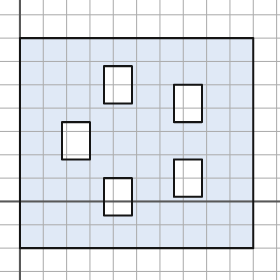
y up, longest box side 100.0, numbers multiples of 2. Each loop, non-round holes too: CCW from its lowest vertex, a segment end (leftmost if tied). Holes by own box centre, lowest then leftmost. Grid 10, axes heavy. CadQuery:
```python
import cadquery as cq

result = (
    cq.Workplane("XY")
    .moveTo(0.0, -20.0)
    .lineTo(100.0, -20.0)
    .lineTo(100.0, 70.0)
    .lineTo(0.0, 70.0)
    .close()
    .moveTo(36.0, -6.0)
    .lineTo(48.0, -6.0)
    .lineTo(48.0, 10.0)
    .lineTo(36.0, 10.0)
    .close()
    .moveTo(66.0, 2.0)
    .lineTo(78.0, 2.0)
    .lineTo(78.0, 18.0)
    .lineTo(66.0, 18.0)
    .close()
    .moveTo(18.0, 18.0)
    .lineTo(30.0, 18.0)
    .lineTo(30.0, 34.0)
    .lineTo(18.0, 34.0)
    .close()
    .moveTo(66.0, 34.0)
    .lineTo(78.0, 34.0)
    .lineTo(78.0, 50.0)
    .lineTo(66.0, 50.0)
    .close()
    .moveTo(36.0, 42.0)
    .lineTo(48.0, 42.0)
    .lineTo(48.0, 58.0)
    .lineTo(36.0, 58.0)
    .close()
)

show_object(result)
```